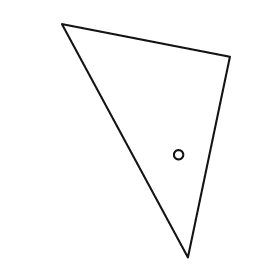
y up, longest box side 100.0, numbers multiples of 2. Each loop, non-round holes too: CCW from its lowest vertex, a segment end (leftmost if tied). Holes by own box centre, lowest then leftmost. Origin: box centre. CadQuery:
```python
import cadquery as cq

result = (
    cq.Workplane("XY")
    .moveTo(18.0, -50.0)
    .lineTo(36.0, 36.0)
    .lineTo(-36.0, 50.0)
    .close()
    .moveTo(14.0, -6.0)
    .circle(2.0)
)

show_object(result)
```